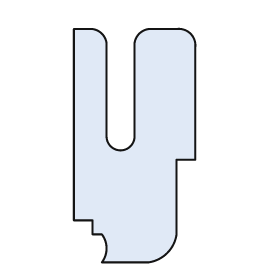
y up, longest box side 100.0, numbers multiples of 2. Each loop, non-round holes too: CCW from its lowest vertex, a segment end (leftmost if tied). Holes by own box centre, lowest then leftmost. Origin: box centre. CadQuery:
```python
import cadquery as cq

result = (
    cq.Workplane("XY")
    .moveTo(-14.0, -50.0)
    .lineTo(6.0, -50.0)
    .threePointArc((14.0, -46.0), (18.0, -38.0))
    .lineTo(18.0, -6.0)
    .lineTo(26.0, -6.0)
    .lineTo(26.0, 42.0)
    .threePointArc((24.0, 48.0), (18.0, 50.0))
    .lineTo(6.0, 50.0)
    .threePointArc((2.0, 48.0), (0.0, 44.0))
    .lineTo(0.0, 4.0)
    .threePointArc((-6.0, -2.0), (-12.0, 4.0))
    .lineTo(-12.0, 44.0)
    .threePointArc((-14.0, 48.0), (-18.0, 50.0))
    .lineTo(-26.0, 50.0)
    .lineTo(-26.0, -32.0)
    .lineTo(-18.0, -32.0)
    .lineTo(-18.0, -38.0)
    .lineTo(-14.0, -38.0)
    .threePointArc((-12.0, -44.0), (-14.0, -50.0))
    .close()
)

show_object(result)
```